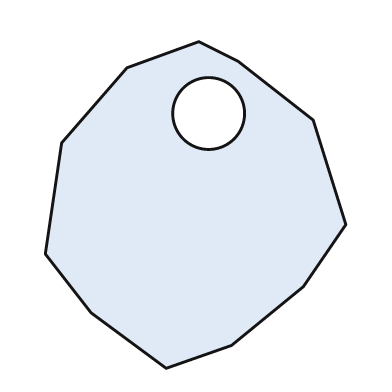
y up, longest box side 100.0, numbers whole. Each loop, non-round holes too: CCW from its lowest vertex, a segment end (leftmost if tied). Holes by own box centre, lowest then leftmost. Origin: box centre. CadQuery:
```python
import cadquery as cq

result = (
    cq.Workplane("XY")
    .moveTo(-9.0, -50.0)
    .lineTo(11.0, -43.0)
    .lineTo(33.0, -25.0)
    .lineTo(46.0, -6.0)
    .lineTo(36.0, 26.0)
    .lineTo(13.0, 44.0)
    .lineTo(1.0, 50.0)
    .lineTo(-21.0, 42.0)
    .lineTo(-41.0, 19.0)
    .lineTo(-46.0, -15.0)
    .lineTo(-32.0, -33.0)
    .close()
    .moveTo(4.0, 28.0)
    .circle(11.0)
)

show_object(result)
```